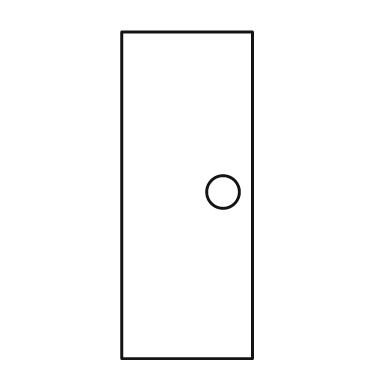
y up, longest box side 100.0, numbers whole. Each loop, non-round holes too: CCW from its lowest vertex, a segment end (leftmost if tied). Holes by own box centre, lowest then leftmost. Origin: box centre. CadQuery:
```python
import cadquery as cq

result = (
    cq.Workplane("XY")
    .moveTo(-20.0, -50.0)
    .lineTo(20.0, -50.0)
    .lineTo(20.0, 50.0)
    .lineTo(-20.0, 50.0)
    .close()
    .moveTo(11.0, 1.0)
    .circle(5.0)
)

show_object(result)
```